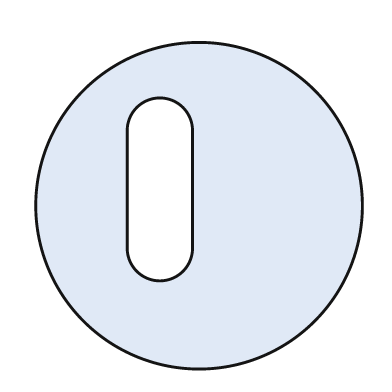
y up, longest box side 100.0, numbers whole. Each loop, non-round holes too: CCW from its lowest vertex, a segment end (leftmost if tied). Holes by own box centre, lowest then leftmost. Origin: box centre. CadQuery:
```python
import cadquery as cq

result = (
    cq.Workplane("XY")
    .moveTo(0.0, 0.0)
    .circle(50.0)
    .moveTo(-22.0, -13.0)
    .threePointArc((-12.0, -23.0), (-2.0, -13.0))
    .lineTo(-2.0, 23.0)
    .threePointArc((-12.0, 33.0), (-22.0, 23.0))
    .close()
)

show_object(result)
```